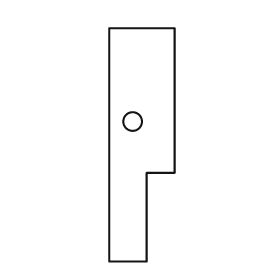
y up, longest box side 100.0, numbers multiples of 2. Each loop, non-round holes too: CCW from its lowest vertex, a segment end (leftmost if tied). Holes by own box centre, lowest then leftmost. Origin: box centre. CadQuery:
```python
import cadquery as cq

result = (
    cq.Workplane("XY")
    .moveTo(-14.0, -50.0)
    .lineTo(2.0, -50.0)
    .lineTo(2.0, -12.0)
    .lineTo(14.0, -12.0)
    .lineTo(14.0, 50.0)
    .lineTo(-14.0, 50.0)
    .close()
    .moveTo(-4.0, 10.0)
    .circle(4.0)
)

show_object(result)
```